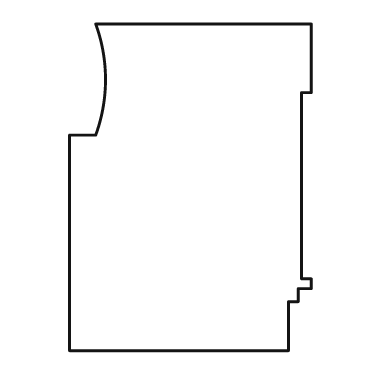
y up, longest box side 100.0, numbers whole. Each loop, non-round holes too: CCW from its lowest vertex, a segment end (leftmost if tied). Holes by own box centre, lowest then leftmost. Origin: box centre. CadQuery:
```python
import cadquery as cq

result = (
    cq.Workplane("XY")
    .moveTo(-37.0, -50.0)
    .lineTo(30.0, -50.0)
    .lineTo(30.0, -35.0)
    .lineTo(33.0, -35.0)
    .lineTo(33.0, -31.0)
    .lineTo(37.0, -31.0)
    .lineTo(37.0, -28.0)
    .lineTo(34.0, -28.0)
    .lineTo(34.0, 29.0)
    .lineTo(37.0, 29.0)
    .lineTo(37.0, 50.0)
    .lineTo(-29.0, 50.0)
    .threePointArc((-26.0, 33.0), (-29.0, 16.0))
    .lineTo(-37.0, 16.0)
    .close()
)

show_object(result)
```